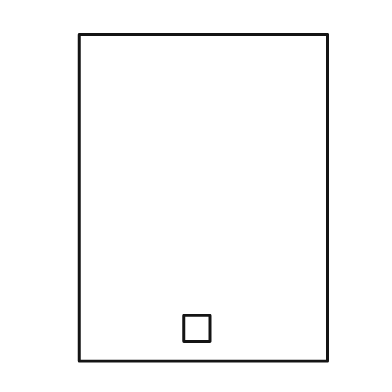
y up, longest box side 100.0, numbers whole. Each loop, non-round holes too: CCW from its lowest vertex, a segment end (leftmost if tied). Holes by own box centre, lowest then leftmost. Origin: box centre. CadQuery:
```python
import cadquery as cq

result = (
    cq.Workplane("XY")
    .moveTo(-38.0, -50.0)
    .lineTo(38.0, -50.0)
    .lineTo(38.0, 50.0)
    .lineTo(-38.0, 50.0)
    .close()
    .moveTo(-6.0, -44.0)
    .lineTo(2.0, -44.0)
    .lineTo(2.0, -36.0)
    .lineTo(-6.0, -36.0)
    .close()
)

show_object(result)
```